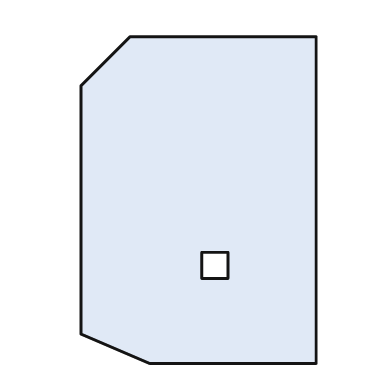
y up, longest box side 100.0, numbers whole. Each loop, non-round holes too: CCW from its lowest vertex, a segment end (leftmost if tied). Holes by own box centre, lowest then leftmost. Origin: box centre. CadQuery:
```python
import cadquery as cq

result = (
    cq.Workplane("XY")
    .moveTo(-15.0, -50.0)
    .lineTo(36.0, -50.0)
    .lineTo(36.0, 50.0)
    .lineTo(-21.0, 50.0)
    .lineTo(-36.0, 35.0)
    .lineTo(-36.0, -41.0)
    .close()
    .moveTo(1.0, -24.0)
    .lineTo(9.0, -24.0)
    .lineTo(9.0, -16.0)
    .lineTo(1.0, -16.0)
    .close()
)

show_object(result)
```